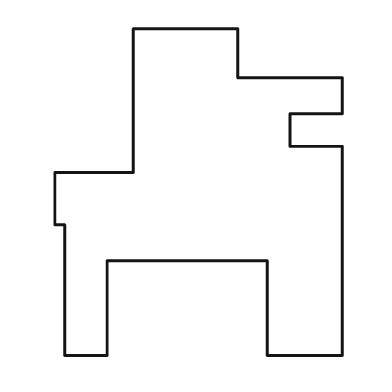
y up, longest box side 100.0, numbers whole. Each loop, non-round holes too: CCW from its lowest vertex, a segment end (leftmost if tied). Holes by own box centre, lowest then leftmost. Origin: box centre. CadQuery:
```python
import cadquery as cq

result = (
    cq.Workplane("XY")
    .moveTo(-41.0, -50.0)
    .lineTo(-28.0, -50.0)
    .lineTo(-28.0, -21.0)
    .lineTo(21.0, -21.0)
    .lineTo(21.0, -50.0)
    .lineTo(44.0, -50.0)
    .lineTo(44.0, 14.0)
    .lineTo(28.0, 14.0)
    .lineTo(28.0, 24.0)
    .lineTo(44.0, 24.0)
    .lineTo(44.0, 35.0)
    .lineTo(12.0, 35.0)
    .lineTo(12.0, 50.0)
    .lineTo(-20.0, 50.0)
    .lineTo(-20.0, 6.0)
    .lineTo(-44.0, 6.0)
    .lineTo(-44.0, -10.0)
    .lineTo(-41.0, -10.0)
    .close()
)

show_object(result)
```